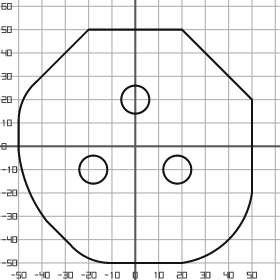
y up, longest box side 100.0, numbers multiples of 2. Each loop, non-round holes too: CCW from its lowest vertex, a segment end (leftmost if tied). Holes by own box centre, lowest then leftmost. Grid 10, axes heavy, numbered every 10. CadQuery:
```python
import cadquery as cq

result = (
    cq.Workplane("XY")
    .moveTo(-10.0, -50.0)
    .lineTo(20.0, -50.0)
    .threePointArc((40.0, -40.0), (50.0, -20.0))
    .lineTo(50.0, 20.0)
    .lineTo(20.0, 50.0)
    .lineTo(-20.0, 50.0)
    .lineTo(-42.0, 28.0)
    .threePointArc((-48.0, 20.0), (-50.0, 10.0))
    .lineTo(-50.0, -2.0)
    .threePointArc((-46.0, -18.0), (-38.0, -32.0))
    .lineTo(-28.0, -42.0)
    .threePointArc((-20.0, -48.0), (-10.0, -50.0))
    .close()
    .moveTo(-18.0, -10.0)
    .circle(6.0)
    .moveTo(18.0, -10.0)
    .circle(6.0)
    .moveTo(0.0, 20.0)
    .circle(6.0)
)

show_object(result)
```